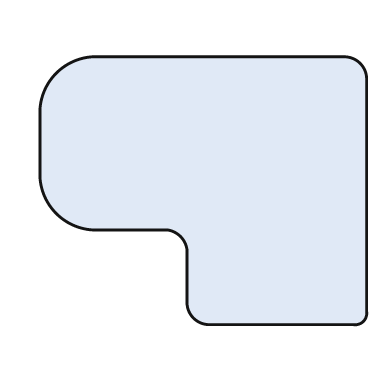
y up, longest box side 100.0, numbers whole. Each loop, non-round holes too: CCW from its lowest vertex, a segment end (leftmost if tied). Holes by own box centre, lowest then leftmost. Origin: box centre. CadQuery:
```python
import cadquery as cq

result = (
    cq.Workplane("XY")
    .moveTo(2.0, -41.0)
    .lineTo(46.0, -41.0)
    .threePointArc((49.0, -40.0), (50.0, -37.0))
    .lineTo(50.0, 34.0)
    .threePointArc((48.0, 39.0), (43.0, 41.0))
    .lineTo(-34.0, 41.0)
    .threePointArc((-45.0, 36.0), (-50.0, 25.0))
    .lineTo(-50.0, 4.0)
    .threePointArc((-45.0, -7.0), (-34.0, -12.0))
    .lineTo(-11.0, -12.0)
    .threePointArc((-7.0, -14.0), (-5.0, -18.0))
    .lineTo(-5.0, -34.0)
    .threePointArc((-3.0, -39.0), (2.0, -41.0))
    .close()
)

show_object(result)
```